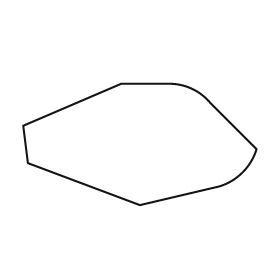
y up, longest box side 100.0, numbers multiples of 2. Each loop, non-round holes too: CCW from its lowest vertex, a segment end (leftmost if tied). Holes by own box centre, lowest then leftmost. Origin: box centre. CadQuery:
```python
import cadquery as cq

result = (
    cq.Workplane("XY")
    .moveTo(0.0, -26.0)
    .lineTo(34.0, -18.0)
    .threePointArc((44.0, -12.0), (50.0, -2.0))
    .lineTo(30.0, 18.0)
    .threePointArc((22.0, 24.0), (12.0, 26.0))
    .lineTo(-8.0, 26.0)
    .lineTo(-50.0, 8.0)
    .lineTo(-48.0, -8.0)
    .close()
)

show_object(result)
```